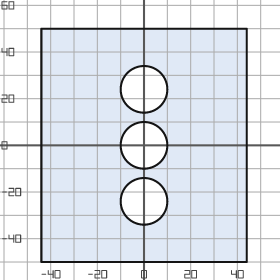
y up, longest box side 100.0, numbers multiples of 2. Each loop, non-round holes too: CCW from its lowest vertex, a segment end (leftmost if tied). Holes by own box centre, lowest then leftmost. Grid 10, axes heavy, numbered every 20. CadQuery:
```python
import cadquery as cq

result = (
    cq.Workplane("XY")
    .moveTo(-44.0, -50.0)
    .lineTo(44.0, -50.0)
    .lineTo(44.0, 50.0)
    .lineTo(-44.0, 50.0)
    .close()
    .moveTo(0.0, -24.0)
    .circle(10.0)
    .moveTo(0.0, 0.0)
    .circle(10.0)
    .moveTo(0.0, 24.0)
    .circle(10.0)
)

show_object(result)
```